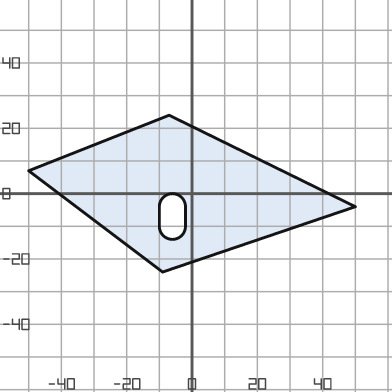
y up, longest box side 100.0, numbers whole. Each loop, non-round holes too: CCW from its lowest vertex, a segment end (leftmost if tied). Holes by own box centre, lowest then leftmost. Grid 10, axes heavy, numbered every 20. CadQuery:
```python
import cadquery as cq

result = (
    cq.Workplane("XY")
    .moveTo(-9.0, -24.0)
    .lineTo(50.0, -4.0)
    .lineTo(-7.0, 24.0)
    .lineTo(-50.0, 7.0)
    .close()
    .moveTo(-10.0, -10.0)
    .threePointArc((-6.0, -14.0), (-2.0, -10.0))
    .lineTo(-2.0, -4.0)
    .threePointArc((-6.0, 0.0), (-10.0, -4.0))
    .close()
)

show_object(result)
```